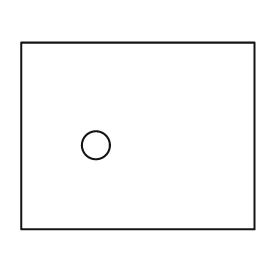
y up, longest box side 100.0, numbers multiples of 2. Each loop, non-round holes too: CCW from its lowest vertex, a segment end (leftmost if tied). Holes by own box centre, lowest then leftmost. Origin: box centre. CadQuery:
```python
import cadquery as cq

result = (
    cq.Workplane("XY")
    .moveTo(-50.0, -40.0)
    .lineTo(50.0, -40.0)
    .lineTo(50.0, 40.0)
    .lineTo(-50.0, 40.0)
    .close()
    .moveTo(-18.0, -4.0)
    .circle(6.0)
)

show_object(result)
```